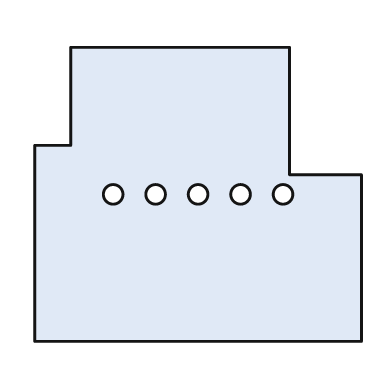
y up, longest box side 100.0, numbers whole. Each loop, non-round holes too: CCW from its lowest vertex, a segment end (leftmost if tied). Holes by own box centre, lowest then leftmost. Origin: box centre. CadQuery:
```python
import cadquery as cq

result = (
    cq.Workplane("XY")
    .moveTo(-50.0, -45.0)
    .lineTo(50.0, -45.0)
    .lineTo(50.0, 6.0)
    .lineTo(28.0, 6.0)
    .lineTo(28.0, 45.0)
    .lineTo(-39.0, 45.0)
    .lineTo(-39.0, 15.0)
    .lineTo(-50.0, 15.0)
    .close()
    .moveTo(-26.0, 0.0)
    .circle(3.0)
    .moveTo(-13.0, 0.0)
    .circle(3.0)
    .moveTo(0.0, 0.0)
    .circle(3.0)
    .moveTo(13.0, 0.0)
    .circle(3.0)
    .moveTo(26.0, 0.0)
    .circle(3.0)
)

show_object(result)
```